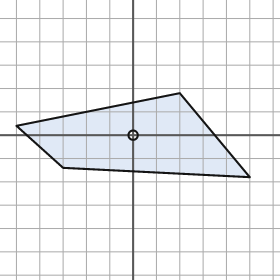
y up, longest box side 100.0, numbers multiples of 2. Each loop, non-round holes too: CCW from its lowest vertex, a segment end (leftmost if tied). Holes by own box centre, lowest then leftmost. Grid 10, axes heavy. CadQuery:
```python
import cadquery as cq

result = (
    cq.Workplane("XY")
    .moveTo(50.0, -18.0)
    .lineTo(20.0, 18.0)
    .lineTo(-50.0, 4.0)
    .lineTo(-30.0, -14.0)
    .close()
    .moveTo(0.0, 0.0)
    .circle(2.0)
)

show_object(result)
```